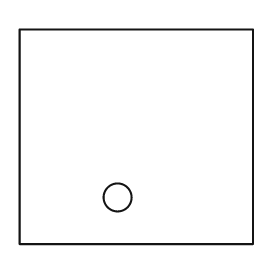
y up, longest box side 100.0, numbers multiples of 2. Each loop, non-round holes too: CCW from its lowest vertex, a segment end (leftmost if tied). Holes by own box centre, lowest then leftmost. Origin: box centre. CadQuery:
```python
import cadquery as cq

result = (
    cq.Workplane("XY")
    .moveTo(-50.0, -46.0)
    .lineTo(50.0, -46.0)
    .lineTo(50.0, 46.0)
    .lineTo(-50.0, 46.0)
    .close()
    .moveTo(-8.0, -26.0)
    .circle(6.0)
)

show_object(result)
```